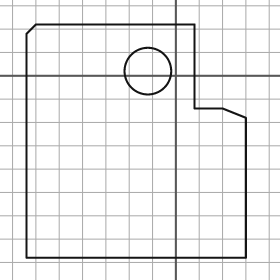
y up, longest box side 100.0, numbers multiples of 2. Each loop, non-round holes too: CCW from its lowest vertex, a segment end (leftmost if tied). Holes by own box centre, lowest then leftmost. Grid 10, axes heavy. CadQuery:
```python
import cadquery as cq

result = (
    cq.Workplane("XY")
    .moveTo(-64.0, -78.0)
    .lineTo(30.0, -78.0)
    .lineTo(30.0, -18.0)
    .lineTo(20.0, -14.0)
    .lineTo(8.0, -14.0)
    .lineTo(8.0, 22.0)
    .lineTo(-60.0, 22.0)
    .lineTo(-64.0, 18.0)
    .close()
    .moveTo(-12.0, 2.0)
    .circle(10.0)
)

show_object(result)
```